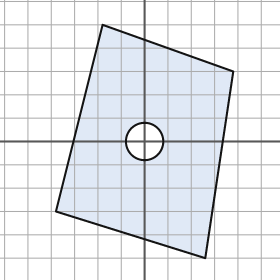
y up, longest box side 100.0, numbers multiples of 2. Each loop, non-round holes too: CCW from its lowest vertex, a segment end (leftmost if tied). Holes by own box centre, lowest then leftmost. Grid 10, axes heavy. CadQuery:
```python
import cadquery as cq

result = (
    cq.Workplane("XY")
    .moveTo(26.0, -50.0)
    .lineTo(38.0, 30.0)
    .lineTo(-18.0, 50.0)
    .lineTo(-38.0, -30.0)
    .close()
    .moveTo(0.0, 0.0)
    .circle(8.0)
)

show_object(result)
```